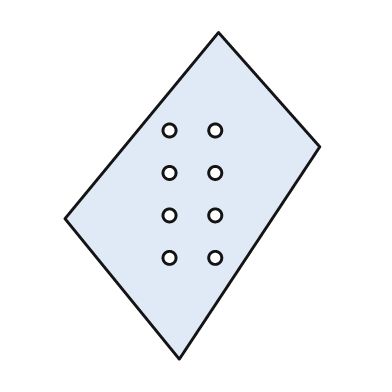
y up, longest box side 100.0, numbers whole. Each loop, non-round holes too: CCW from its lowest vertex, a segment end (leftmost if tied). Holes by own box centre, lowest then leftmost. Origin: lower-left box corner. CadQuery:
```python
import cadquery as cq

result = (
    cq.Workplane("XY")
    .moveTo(35.0, 0.0)
    .lineTo(78.0, 65.0)
    .lineTo(47.0, 100.0)
    .lineTo(0.0, 43.0)
    .close()
    .moveTo(32.0, 31.0)
    .circle(2.0)
    .moveTo(46.0, 31.0)
    .circle(2.0)
    .moveTo(32.0, 44.0)
    .circle(2.0)
    .moveTo(46.0, 44.0)
    .circle(2.0)
    .moveTo(32.0, 57.0)
    .circle(2.0)
    .moveTo(46.0, 57.0)
    .circle(2.0)
    .moveTo(32.0, 70.0)
    .circle(2.0)
    .moveTo(46.0, 70.0)
    .circle(2.0)
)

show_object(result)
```